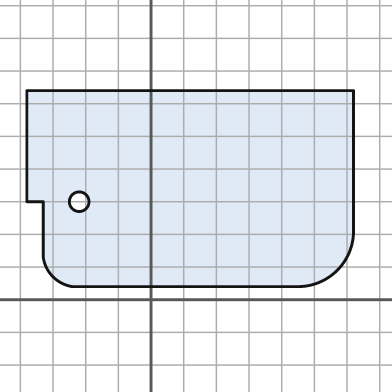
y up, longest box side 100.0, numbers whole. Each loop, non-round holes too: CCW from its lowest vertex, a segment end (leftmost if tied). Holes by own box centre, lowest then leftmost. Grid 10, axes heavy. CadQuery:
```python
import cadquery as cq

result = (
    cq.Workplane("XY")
    .moveTo(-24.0, 4.0)
    .lineTo(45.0, 4.0)
    .threePointArc((57.0, 9.0), (62.0, 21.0))
    .lineTo(62.0, 64.0)
    .lineTo(-38.0, 64.0)
    .lineTo(-38.0, 30.0)
    .lineTo(-33.0, 30.0)
    .lineTo(-33.0, 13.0)
    .threePointArc((-30.0, 7.0), (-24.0, 4.0))
    .close()
    .moveTo(-22.0, 30.0)
    .circle(3.0)
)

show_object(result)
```